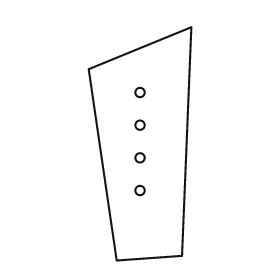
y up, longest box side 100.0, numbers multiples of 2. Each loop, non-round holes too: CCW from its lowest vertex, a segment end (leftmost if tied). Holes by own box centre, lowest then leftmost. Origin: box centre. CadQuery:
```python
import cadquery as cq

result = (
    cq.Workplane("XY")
    .moveTo(-10.0, -50.0)
    .lineTo(18.0, -48.0)
    .lineTo(22.0, 50.0)
    .lineTo(-22.0, 32.0)
    .close()
    .moveTo(0.0, -20.0)
    .circle(2.0)
    .moveTo(0.0, -6.0)
    .circle(2.0)
    .moveTo(0.0, 8.0)
    .circle(2.0)
    .moveTo(0.0, 22.0)
    .circle(2.0)
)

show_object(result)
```